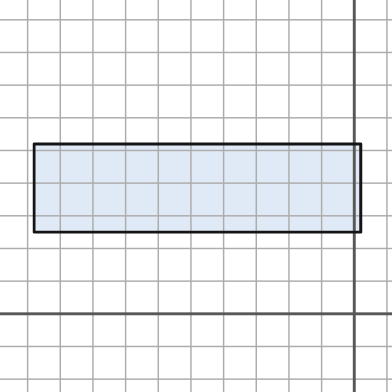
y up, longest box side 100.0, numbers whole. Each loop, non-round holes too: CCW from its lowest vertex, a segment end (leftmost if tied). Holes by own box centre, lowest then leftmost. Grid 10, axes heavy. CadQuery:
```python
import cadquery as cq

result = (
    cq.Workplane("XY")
    .moveTo(-98.0, 25.0)
    .lineTo(2.0, 25.0)
    .lineTo(2.0, 52.0)
    .lineTo(-98.0, 52.0)
    .close()
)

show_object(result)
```